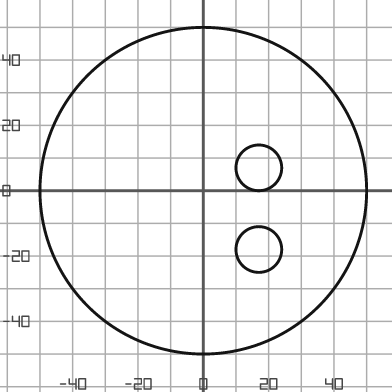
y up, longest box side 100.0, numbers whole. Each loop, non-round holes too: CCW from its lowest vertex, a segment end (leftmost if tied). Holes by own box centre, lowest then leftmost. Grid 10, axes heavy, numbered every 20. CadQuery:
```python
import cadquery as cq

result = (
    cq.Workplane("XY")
    .moveTo(0.0, 0.0)
    .circle(50.0)
    .moveTo(17.0, -18.0)
    .circle(7.0)
    .moveTo(17.0, 7.0)
    .circle(7.0)
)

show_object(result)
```